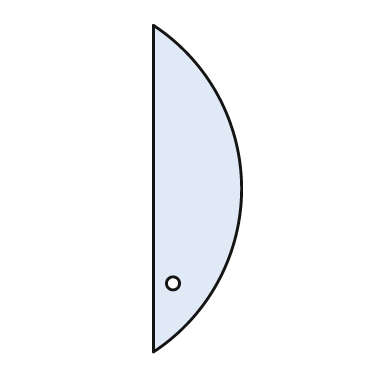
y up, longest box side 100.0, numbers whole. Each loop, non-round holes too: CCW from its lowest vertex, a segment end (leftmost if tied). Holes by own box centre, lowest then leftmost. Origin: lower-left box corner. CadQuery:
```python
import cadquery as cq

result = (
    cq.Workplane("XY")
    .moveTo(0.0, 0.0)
    .threePointArc((27.0, 50.0), (0.0, 100.0))
    .close()
    .moveTo(6.0, 21.0)
    .circle(2.0)
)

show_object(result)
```